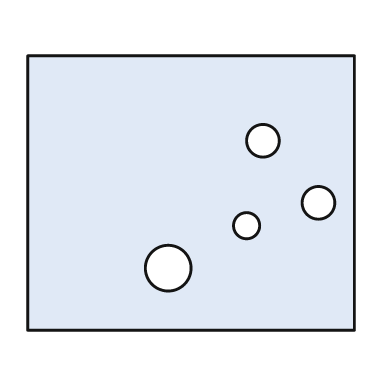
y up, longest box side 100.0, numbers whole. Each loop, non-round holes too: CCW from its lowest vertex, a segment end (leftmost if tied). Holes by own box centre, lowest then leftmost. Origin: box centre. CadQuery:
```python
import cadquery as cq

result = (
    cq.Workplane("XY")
    .moveTo(-50.0, -42.0)
    .lineTo(50.0, -42.0)
    .lineTo(50.0, 42.0)
    .lineTo(-50.0, 42.0)
    .close()
    .moveTo(-7.0, -23.0)
    .circle(7.0)
    .moveTo(17.0, -10.0)
    .circle(4.0)
    .moveTo(39.0, -3.0)
    .circle(5.0)
    .moveTo(22.0, 16.0)
    .circle(5.0)
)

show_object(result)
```